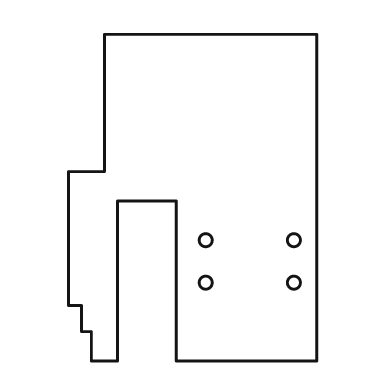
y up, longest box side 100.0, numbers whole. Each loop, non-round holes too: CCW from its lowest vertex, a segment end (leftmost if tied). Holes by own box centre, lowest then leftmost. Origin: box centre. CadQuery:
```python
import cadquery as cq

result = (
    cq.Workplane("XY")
    .moveTo(-31.0, -50.0)
    .lineTo(-23.0, -50.0)
    .lineTo(-23.0, -1.0)
    .lineTo(-5.0, -1.0)
    .lineTo(-5.0, -50.0)
    .lineTo(38.0, -50.0)
    .lineTo(38.0, 50.0)
    .lineTo(-27.0, 50.0)
    .lineTo(-27.0, 8.0)
    .lineTo(-38.0, 8.0)
    .lineTo(-38.0, -33.0)
    .lineTo(-34.0, -33.0)
    .lineTo(-34.0, -41.0)
    .lineTo(-31.0, -41.0)
    .close()
    .moveTo(4.0, -26.0)
    .circle(2.0)
    .moveTo(31.0, -26.0)
    .circle(2.0)
    .moveTo(4.0, -13.0)
    .circle(2.0)
    .moveTo(31.0, -13.0)
    .circle(2.0)
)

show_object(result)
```